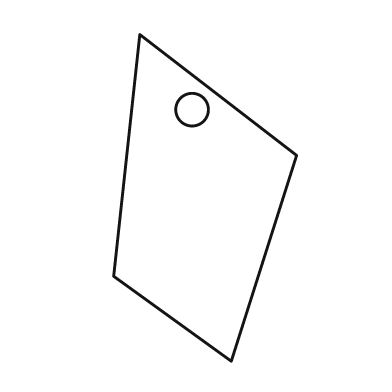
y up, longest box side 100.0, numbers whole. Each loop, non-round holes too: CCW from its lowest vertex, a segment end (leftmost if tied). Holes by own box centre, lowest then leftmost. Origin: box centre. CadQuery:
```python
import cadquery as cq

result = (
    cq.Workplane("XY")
    .moveTo(8.0, -50.0)
    .lineTo(28.0, 13.0)
    .lineTo(-20.0, 50.0)
    .lineTo(-28.0, -24.0)
    .close()
    .moveTo(-4.0, 27.0)
    .circle(5.0)
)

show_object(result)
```